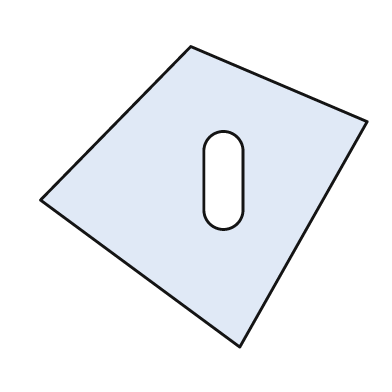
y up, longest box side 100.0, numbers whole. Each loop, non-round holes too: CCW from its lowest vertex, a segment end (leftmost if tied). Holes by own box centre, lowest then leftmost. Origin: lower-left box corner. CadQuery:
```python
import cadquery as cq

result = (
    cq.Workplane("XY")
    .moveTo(61.0, 0.0)
    .lineTo(100.0, 69.0)
    .lineTo(46.0, 92.0)
    .lineTo(0.0, 45.0)
    .close()
    .moveTo(50.0, 42.0)
    .threePointArc((56.0, 36.0), (62.0, 42.0))
    .lineTo(62.0, 60.0)
    .threePointArc((56.0, 66.0), (50.0, 60.0))
    .close()
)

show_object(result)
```